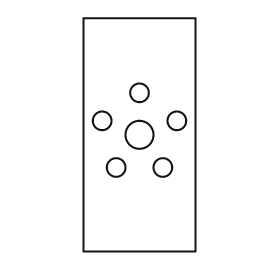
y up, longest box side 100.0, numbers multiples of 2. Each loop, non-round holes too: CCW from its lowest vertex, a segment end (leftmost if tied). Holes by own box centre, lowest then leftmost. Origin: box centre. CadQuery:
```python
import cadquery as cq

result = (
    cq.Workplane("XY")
    .moveTo(-24.0, -50.0)
    .lineTo(24.0, -50.0)
    .lineTo(24.0, 50.0)
    .lineTo(-24.0, 50.0)
    .close()
    .moveTo(-10.0, -14.0)
    .circle(4.0)
    .moveTo(10.0, -14.0)
    .circle(4.0)
    .moveTo(0.0, 0.0)
    .circle(6.0)
    .moveTo(-16.0, 6.0)
    .circle(4.0)
    .moveTo(16.0, 6.0)
    .circle(4.0)
    .moveTo(0.0, 18.0)
    .circle(4.0)
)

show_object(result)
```